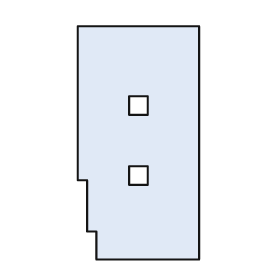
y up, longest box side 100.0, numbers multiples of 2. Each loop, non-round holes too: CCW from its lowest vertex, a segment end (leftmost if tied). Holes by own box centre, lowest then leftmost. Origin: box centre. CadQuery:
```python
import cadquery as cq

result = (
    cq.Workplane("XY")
    .moveTo(-18.0, -50.0)
    .lineTo(26.0, -50.0)
    .lineTo(26.0, 50.0)
    .lineTo(-26.0, 50.0)
    .lineTo(-26.0, -16.0)
    .lineTo(-22.0, -16.0)
    .lineTo(-22.0, -38.0)
    .lineTo(-18.0, -38.0)
    .close()
    .moveTo(-4.0, -18.0)
    .lineTo(4.0, -18.0)
    .lineTo(4.0, -10.0)
    .lineTo(-4.0, -10.0)
    .close()
    .moveTo(-4.0, 12.0)
    .lineTo(4.0, 12.0)
    .lineTo(4.0, 20.0)
    .lineTo(-4.0, 20.0)
    .close()
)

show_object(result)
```